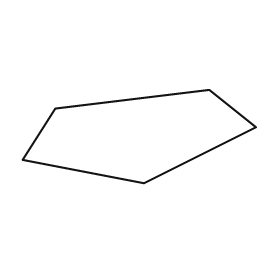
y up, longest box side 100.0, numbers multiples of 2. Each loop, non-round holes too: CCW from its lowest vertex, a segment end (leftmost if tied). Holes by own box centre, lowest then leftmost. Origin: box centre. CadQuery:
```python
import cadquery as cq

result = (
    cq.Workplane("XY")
    .moveTo(2.0, -20.0)
    .lineTo(50.0, 4.0)
    .lineTo(30.0, 20.0)
    .lineTo(-36.0, 12.0)
    .lineTo(-50.0, -10.0)
    .close()
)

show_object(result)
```